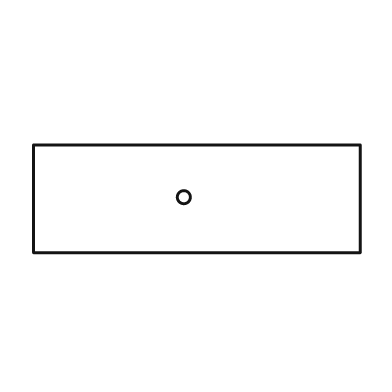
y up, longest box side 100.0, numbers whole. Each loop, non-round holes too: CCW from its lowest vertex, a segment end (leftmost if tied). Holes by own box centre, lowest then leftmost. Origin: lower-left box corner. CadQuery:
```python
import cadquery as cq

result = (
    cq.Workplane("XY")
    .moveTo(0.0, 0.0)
    .lineTo(100.0, 0.0)
    .lineTo(100.0, 33.0)
    .lineTo(0.0, 33.0)
    .close()
    .moveTo(46.0, 17.0)
    .circle(2.0)
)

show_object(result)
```